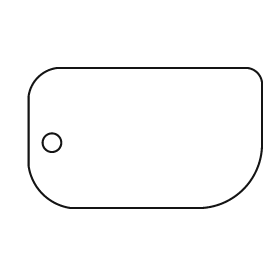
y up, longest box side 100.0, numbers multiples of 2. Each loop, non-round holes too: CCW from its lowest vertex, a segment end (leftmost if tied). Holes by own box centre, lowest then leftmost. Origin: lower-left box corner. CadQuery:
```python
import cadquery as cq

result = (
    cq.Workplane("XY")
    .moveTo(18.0, 0.0)
    .lineTo(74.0, 0.0)
    .threePointArc((92.0, 8.0), (100.0, 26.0))
    .lineTo(100.0, 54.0)
    .threePointArc((98.0, 58.0), (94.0, 60.0))
    .lineTo(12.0, 60.0)
    .threePointArc((4.0, 56.0), (0.0, 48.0))
    .lineTo(0.0, 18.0)
    .threePointArc((6.0, 6.0), (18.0, 0.0))
    .close()
    .moveTo(10.0, 28.0)
    .circle(4.0)
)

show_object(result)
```